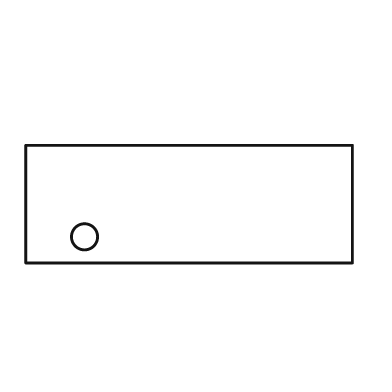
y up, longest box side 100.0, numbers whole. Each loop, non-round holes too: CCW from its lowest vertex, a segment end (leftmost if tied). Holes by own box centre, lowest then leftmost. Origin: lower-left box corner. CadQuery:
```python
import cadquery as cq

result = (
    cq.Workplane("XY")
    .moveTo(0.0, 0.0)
    .lineTo(100.0, 0.0)
    .lineTo(100.0, 36.0)
    .lineTo(0.0, 36.0)
    .close()
    .moveTo(18.0, 8.0)
    .circle(4.0)
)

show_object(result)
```